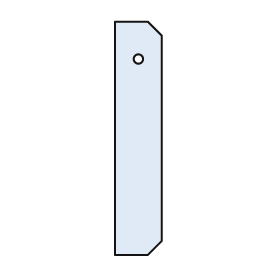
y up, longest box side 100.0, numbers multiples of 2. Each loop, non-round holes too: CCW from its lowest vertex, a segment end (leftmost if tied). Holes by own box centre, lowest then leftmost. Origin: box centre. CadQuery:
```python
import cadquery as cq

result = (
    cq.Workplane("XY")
    .moveTo(-10.0, -50.0)
    .lineTo(4.0, -50.0)
    .lineTo(10.0, -44.0)
    .lineTo(10.0, 44.0)
    .lineTo(4.0, 50.0)
    .lineTo(-10.0, 50.0)
    .close()
    .moveTo(0.0, 34.0)
    .circle(2.0)
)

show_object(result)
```